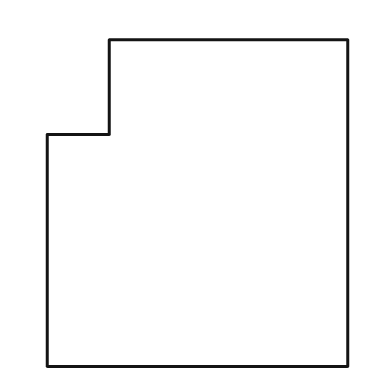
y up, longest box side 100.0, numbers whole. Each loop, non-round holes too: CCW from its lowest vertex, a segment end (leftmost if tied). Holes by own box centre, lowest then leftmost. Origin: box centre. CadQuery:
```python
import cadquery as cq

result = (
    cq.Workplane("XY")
    .moveTo(-46.0, -50.0)
    .lineTo(46.0, -50.0)
    .lineTo(46.0, 50.0)
    .lineTo(-27.0, 50.0)
    .lineTo(-27.0, 21.0)
    .lineTo(-46.0, 21.0)
    .close()
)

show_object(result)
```